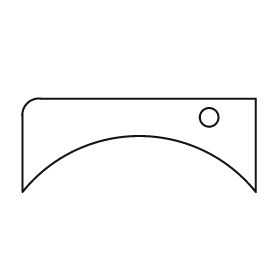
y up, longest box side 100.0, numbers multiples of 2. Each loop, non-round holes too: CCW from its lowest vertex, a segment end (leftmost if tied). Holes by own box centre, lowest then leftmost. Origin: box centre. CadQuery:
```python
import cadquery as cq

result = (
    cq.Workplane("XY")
    .moveTo(-50.0, -20.0)
    .threePointArc((0.0, 4.0), (50.0, -20.0))
    .lineTo(50.0, 20.0)
    .lineTo(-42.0, 20.0)
    .threePointArc((-48.0, 18.0), (-50.0, 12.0))
    .close()
    .moveTo(30.0, 12.0)
    .circle(4.0)
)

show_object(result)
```